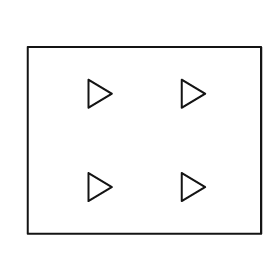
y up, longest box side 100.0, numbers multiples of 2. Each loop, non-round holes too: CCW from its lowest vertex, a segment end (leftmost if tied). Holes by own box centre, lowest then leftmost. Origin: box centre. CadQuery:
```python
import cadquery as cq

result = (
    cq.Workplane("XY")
    .moveTo(-50.0, -40.0)
    .lineTo(50.0, -40.0)
    .lineTo(50.0, 40.0)
    .lineTo(-50.0, 40.0)
    .close()
    .moveTo(-24.0, -26.0)
    .lineTo(-14.0, -20.0)
    .lineTo(-24.0, -14.0)
    .close()
    .moveTo(16.0, -26.0)
    .lineTo(26.0, -20.0)
    .lineTo(16.0, -14.0)
    .close()
    .moveTo(-24.0, 14.0)
    .lineTo(-14.0, 20.0)
    .lineTo(-24.0, 26.0)
    .close()
    .moveTo(16.0, 14.0)
    .lineTo(26.0, 20.0)
    .lineTo(16.0, 26.0)
    .close()
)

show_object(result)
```